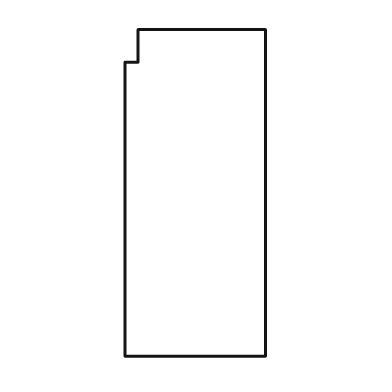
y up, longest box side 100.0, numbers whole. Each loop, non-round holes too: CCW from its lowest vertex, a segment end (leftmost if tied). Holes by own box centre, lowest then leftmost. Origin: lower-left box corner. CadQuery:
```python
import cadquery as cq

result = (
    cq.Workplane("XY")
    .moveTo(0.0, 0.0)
    .lineTo(43.0, 0.0)
    .lineTo(43.0, 100.0)
    .lineTo(4.0, 100.0)
    .lineTo(4.0, 90.0)
    .lineTo(0.0, 90.0)
    .close()
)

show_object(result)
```